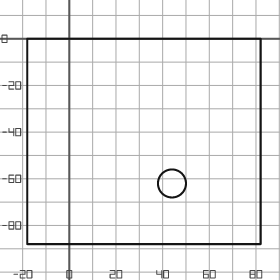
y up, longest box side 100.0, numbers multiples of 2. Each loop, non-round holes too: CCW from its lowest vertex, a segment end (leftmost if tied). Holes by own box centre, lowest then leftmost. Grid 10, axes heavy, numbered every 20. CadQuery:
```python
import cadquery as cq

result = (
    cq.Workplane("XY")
    .moveTo(-18.0, -88.0)
    .lineTo(82.0, -88.0)
    .lineTo(82.0, 0.0)
    .lineTo(-18.0, 0.0)
    .close()
    .moveTo(44.0, -62.0)
    .circle(6.0)
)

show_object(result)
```